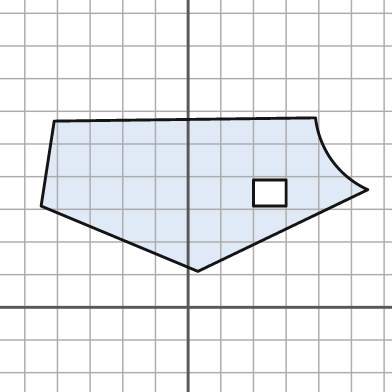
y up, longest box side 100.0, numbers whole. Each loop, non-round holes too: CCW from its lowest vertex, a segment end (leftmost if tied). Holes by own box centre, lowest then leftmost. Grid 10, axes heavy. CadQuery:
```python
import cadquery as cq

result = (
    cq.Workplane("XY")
    .moveTo(3.0, 11.0)
    .lineTo(55.0, 36.0)
    .threePointArc((44.0, 45.0), (39.0, 58.0))
    .lineTo(-41.0, 57.0)
    .lineTo(-45.0, 31.0)
    .close()
    .moveTo(20.0, 31.0)
    .lineTo(30.0, 31.0)
    .lineTo(30.0, 39.0)
    .lineTo(20.0, 39.0)
    .close()
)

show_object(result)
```